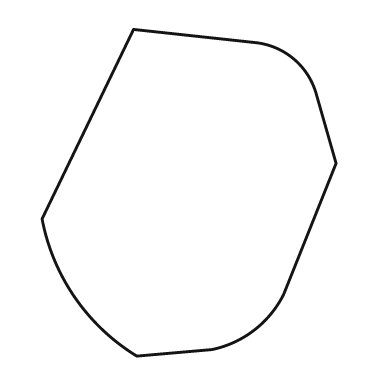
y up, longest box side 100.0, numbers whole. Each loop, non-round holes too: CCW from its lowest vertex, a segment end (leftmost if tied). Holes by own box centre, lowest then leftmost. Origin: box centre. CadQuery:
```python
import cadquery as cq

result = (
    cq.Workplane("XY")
    .moveTo(-16.0, -50.0)
    .lineTo(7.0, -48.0)
    .threePointArc((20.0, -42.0), (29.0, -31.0))
    .lineTo(45.0, 9.0)
    .lineTo(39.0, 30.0)
    .threePointArc((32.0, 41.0), (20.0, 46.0))
    .lineTo(-17.0, 50.0)
    .lineTo(-45.0, -8.0)
    .threePointArc((-35.0, -32.0), (-16.0, -50.0))
    .close()
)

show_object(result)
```